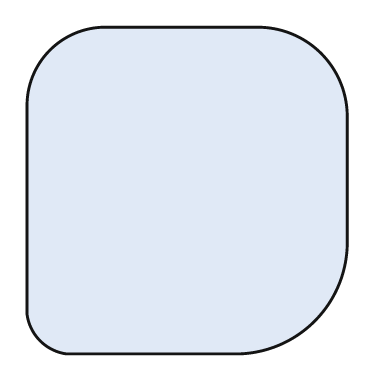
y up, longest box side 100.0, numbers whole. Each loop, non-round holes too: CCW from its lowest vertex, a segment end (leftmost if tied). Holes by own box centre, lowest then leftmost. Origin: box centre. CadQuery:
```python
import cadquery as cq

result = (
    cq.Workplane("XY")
    .moveTo(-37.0, -50.0)
    .lineTo(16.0, -50.0)
    .threePointArc((39.0, -40.0), (49.0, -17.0))
    .lineTo(49.0, 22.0)
    .threePointArc((41.0, 42.0), (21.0, 50.0))
    .lineTo(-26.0, 50.0)
    .threePointArc((-42.0, 43.0), (-49.0, 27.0))
    .lineTo(-49.0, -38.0)
    .threePointArc((-45.0, -46.0), (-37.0, -50.0))
    .close()
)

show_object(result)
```